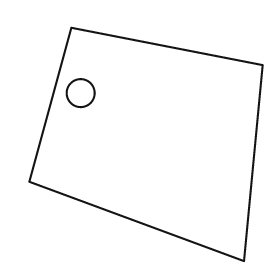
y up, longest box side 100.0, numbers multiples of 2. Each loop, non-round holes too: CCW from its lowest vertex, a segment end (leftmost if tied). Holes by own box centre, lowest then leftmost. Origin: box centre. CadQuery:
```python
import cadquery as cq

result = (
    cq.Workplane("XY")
    .moveTo(42.0, -50.0)
    .lineTo(50.0, 34.0)
    .lineTo(-32.0, 50.0)
    .lineTo(-50.0, -16.0)
    .close()
    .moveTo(-28.0, 22.0)
    .circle(6.0)
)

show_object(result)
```